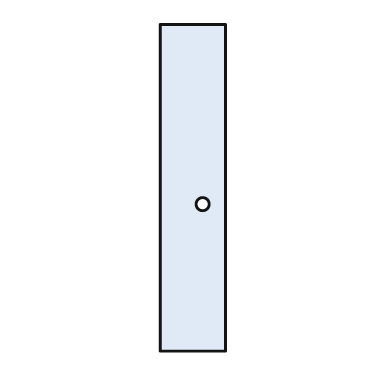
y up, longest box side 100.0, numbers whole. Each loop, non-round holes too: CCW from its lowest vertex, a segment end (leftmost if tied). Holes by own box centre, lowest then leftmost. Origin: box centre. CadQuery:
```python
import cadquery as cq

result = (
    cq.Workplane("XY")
    .moveTo(-10.0, -50.0)
    .lineTo(10.0, -50.0)
    .lineTo(10.0, 50.0)
    .lineTo(-10.0, 50.0)
    .close()
    .moveTo(3.0, -5.0)
    .circle(2.0)
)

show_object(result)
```